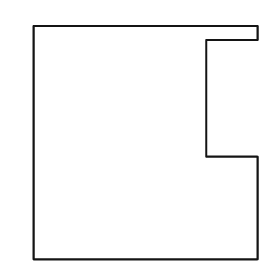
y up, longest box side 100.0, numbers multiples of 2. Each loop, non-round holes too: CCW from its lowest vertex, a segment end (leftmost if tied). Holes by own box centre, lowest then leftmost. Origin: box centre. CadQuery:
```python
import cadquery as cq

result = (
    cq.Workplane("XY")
    .moveTo(-48.0, -50.0)
    .lineTo(48.0, -50.0)
    .lineTo(48.0, -6.0)
    .lineTo(26.0, -6.0)
    .lineTo(26.0, 44.0)
    .lineTo(48.0, 44.0)
    .lineTo(48.0, 50.0)
    .lineTo(-48.0, 50.0)
    .close()
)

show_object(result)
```